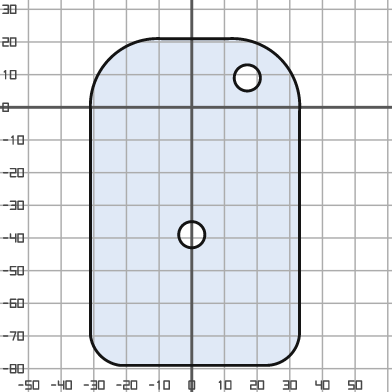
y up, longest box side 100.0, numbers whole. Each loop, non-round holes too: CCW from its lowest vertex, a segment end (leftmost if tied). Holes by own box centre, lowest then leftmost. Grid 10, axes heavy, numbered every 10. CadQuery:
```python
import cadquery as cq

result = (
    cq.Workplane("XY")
    .moveTo(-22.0, -79.0)
    .lineTo(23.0, -79.0)
    .threePointArc((30.0, -76.0), (33.0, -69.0))
    .lineTo(33.0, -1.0)
    .threePointArc((27.0, 15.0), (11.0, 21.0))
    .lineTo(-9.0, 21.0)
    .threePointArc((-25.0, 15.0), (-31.0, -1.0))
    .lineTo(-31.0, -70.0)
    .threePointArc((-28.0, -76.0), (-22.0, -79.0))
    .close()
    .moveTo(0.0, -39.0)
    .circle(4.0)
    .moveTo(17.0, 9.0)
    .circle(4.0)
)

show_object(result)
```